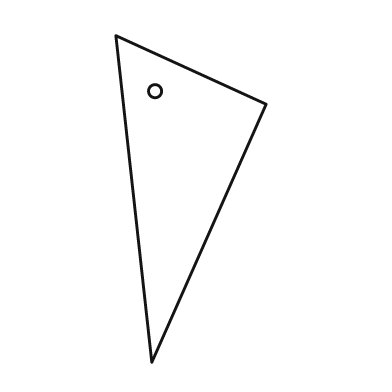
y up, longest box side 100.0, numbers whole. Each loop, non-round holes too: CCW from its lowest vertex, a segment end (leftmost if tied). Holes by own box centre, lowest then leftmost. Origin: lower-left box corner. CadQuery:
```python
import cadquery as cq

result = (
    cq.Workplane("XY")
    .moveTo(11.0, 0.0)
    .lineTo(46.0, 79.0)
    .lineTo(0.0, 100.0)
    .close()
    .moveTo(12.0, 83.0)
    .circle(2.0)
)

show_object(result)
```